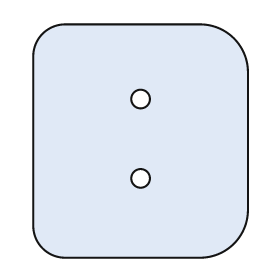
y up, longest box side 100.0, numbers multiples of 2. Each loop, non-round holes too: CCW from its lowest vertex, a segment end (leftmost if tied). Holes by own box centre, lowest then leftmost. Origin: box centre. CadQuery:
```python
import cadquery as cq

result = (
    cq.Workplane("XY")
    .moveTo(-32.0, -50.0)
    .lineTo(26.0, -50.0)
    .threePointArc((40.0, -44.0), (46.0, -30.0))
    .lineTo(46.0, 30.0)
    .threePointArc((40.0, 44.0), (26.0, 50.0))
    .lineTo(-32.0, 50.0)
    .threePointArc((-42.0, 46.0), (-46.0, 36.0))
    .lineTo(-46.0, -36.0)
    .threePointArc((-42.0, -46.0), (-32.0, -50.0))
    .close()
    .moveTo(0.0, -16.0)
    .circle(4.0)
    .moveTo(0.0, 18.0)
    .circle(4.0)
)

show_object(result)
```